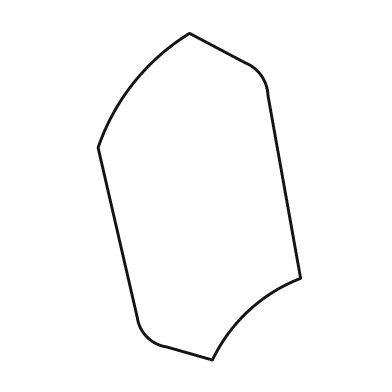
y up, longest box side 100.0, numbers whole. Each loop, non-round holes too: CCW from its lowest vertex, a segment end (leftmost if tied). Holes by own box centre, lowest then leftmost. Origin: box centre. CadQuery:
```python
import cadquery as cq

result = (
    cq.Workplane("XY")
    .moveTo(4.0, -50.0)
    .threePointArc((15.0, -35.0), (31.0, -25.0))
    .lineTo(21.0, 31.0)
    .threePointArc((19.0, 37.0), (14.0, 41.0))
    .lineTo(-3.0, 50.0)
    .threePointArc((-20.0, 35.0), (-31.0, 15.0))
    .lineTo(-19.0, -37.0)
    .threePointArc((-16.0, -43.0), (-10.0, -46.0))
    .close()
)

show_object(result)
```